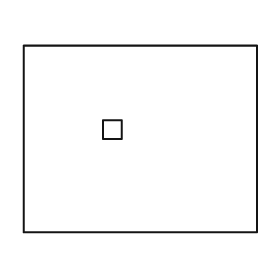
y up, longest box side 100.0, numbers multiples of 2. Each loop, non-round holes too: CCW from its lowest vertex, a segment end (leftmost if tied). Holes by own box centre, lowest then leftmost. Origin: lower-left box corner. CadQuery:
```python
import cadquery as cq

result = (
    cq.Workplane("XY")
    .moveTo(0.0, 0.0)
    .lineTo(100.0, 0.0)
    .lineTo(100.0, 80.0)
    .lineTo(0.0, 80.0)
    .close()
    .moveTo(34.0, 40.0)
    .lineTo(42.0, 40.0)
    .lineTo(42.0, 48.0)
    .lineTo(34.0, 48.0)
    .close()
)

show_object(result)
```